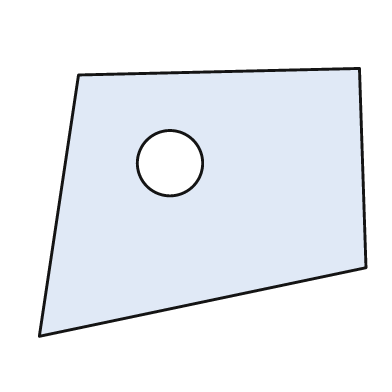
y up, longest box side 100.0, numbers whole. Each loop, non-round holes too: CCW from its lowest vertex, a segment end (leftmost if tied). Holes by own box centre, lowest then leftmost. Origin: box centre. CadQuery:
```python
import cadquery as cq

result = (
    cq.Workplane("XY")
    .moveTo(-50.0, -41.0)
    .lineTo(50.0, -20.0)
    .lineTo(48.0, 41.0)
    .lineTo(-38.0, 39.0)
    .close()
    .moveTo(-10.0, 12.0)
    .circle(10.0)
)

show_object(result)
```